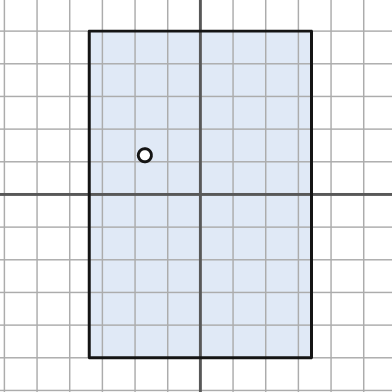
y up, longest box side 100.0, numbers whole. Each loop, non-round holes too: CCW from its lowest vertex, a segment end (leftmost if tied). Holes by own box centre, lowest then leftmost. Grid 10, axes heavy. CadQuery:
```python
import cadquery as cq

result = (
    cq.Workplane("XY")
    .moveTo(-34.0, -50.0)
    .lineTo(34.0, -50.0)
    .lineTo(34.0, 50.0)
    .lineTo(-34.0, 50.0)
    .close()
    .moveTo(-17.0, 12.0)
    .circle(2.0)
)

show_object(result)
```